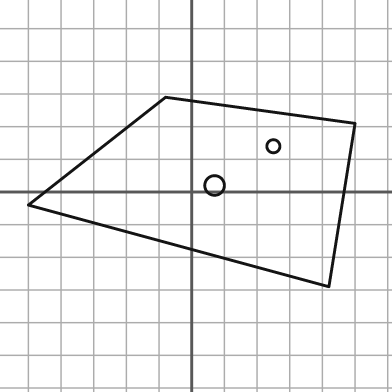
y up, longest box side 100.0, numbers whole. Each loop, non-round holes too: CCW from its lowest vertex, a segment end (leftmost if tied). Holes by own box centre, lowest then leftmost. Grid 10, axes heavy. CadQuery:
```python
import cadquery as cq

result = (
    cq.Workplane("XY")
    .moveTo(42.0, -29.0)
    .lineTo(50.0, 21.0)
    .lineTo(-8.0, 29.0)
    .lineTo(-50.0, -4.0)
    .close()
    .moveTo(7.0, 2.0)
    .circle(3.0)
    .moveTo(25.0, 14.0)
    .circle(2.0)
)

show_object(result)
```